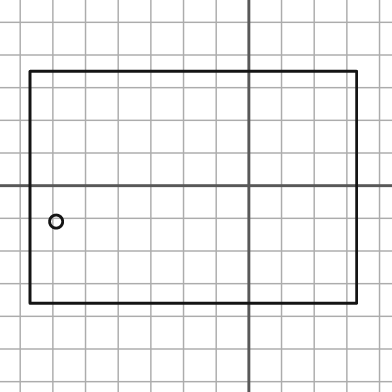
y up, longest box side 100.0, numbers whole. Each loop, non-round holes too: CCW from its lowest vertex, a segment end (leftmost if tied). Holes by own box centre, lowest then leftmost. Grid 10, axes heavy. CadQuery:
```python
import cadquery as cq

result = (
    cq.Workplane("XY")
    .moveTo(-67.0, -36.0)
    .lineTo(33.0, -36.0)
    .lineTo(33.0, 35.0)
    .lineTo(-67.0, 35.0)
    .close()
    .moveTo(-59.0, -11.0)
    .circle(2.0)
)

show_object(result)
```